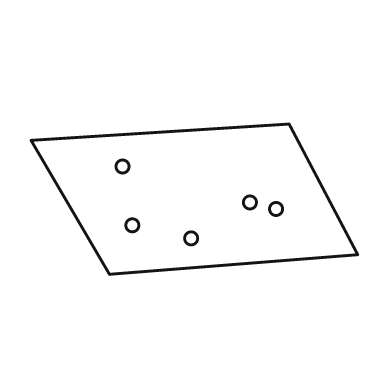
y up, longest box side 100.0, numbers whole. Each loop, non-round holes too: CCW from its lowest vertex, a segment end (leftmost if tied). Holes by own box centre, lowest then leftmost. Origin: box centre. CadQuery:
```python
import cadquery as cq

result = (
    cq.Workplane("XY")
    .moveTo(-26.0, -23.0)
    .lineTo(50.0, -17.0)
    .lineTo(29.0, 23.0)
    .lineTo(-50.0, 18.0)
    .close()
    .moveTo(-1.0, -12.0)
    .circle(2.0)
    .moveTo(-19.0, -8.0)
    .circle(2.0)
    .moveTo(25.0, -3.0)
    .circle(2.0)
    .moveTo(17.0, -1.0)
    .circle(2.0)
    .moveTo(-22.0, 10.0)
    .circle(2.0)
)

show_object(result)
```